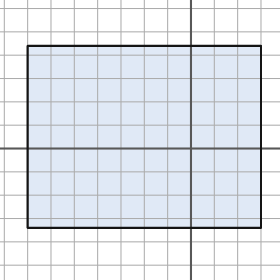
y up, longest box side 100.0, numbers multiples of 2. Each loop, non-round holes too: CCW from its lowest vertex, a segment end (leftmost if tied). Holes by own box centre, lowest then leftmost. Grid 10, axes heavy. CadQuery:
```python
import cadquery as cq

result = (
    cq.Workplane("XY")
    .moveTo(-70.0, -34.0)
    .lineTo(30.0, -34.0)
    .lineTo(30.0, 44.0)
    .lineTo(-70.0, 44.0)
    .close()
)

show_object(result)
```